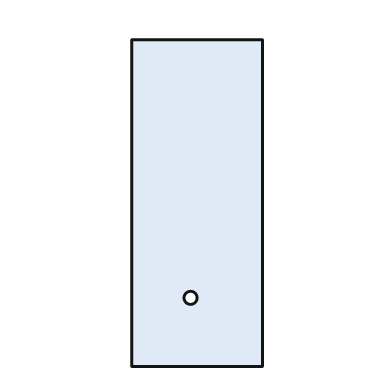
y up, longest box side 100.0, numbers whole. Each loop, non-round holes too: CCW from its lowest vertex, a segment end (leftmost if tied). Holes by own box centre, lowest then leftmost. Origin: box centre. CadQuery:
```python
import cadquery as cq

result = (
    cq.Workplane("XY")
    .moveTo(-20.0, -50.0)
    .lineTo(20.0, -50.0)
    .lineTo(20.0, 50.0)
    .lineTo(-20.0, 50.0)
    .close()
    .moveTo(-2.0, -29.0)
    .circle(2.0)
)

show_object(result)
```